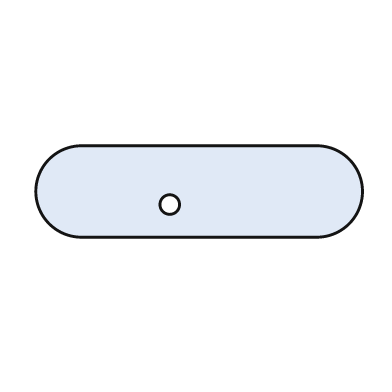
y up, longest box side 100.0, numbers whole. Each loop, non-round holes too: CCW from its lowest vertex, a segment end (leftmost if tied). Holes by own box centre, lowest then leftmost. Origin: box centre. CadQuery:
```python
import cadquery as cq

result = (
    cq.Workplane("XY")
    .moveTo(-36.0, -14.0)
    .lineTo(36.0, -14.0)
    .threePointArc((50.0, 0.0), (36.0, 14.0))
    .lineTo(-36.0, 14.0)
    .threePointArc((-50.0, 0.0), (-36.0, -14.0))
    .close()
    .moveTo(-9.0, -4.0)
    .circle(3.0)
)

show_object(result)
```